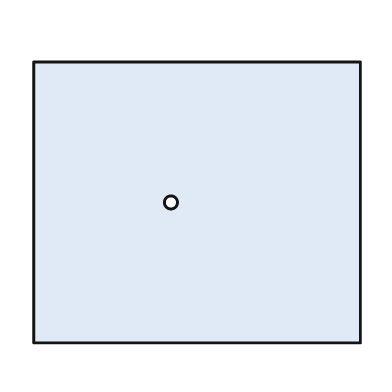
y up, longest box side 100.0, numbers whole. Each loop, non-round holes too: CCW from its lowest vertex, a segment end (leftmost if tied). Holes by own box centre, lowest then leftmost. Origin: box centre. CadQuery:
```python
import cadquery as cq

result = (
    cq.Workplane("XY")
    .moveTo(-50.0, -43.0)
    .lineTo(50.0, -43.0)
    .lineTo(50.0, 43.0)
    .lineTo(-50.0, 43.0)
    .close()
    .moveTo(-8.0, 0.0)
    .circle(2.0)
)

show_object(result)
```